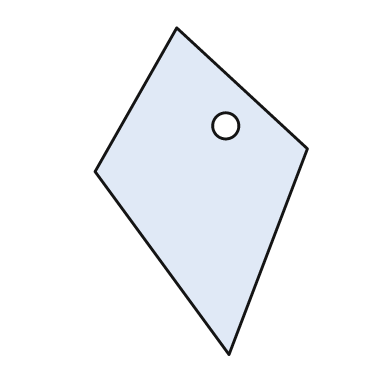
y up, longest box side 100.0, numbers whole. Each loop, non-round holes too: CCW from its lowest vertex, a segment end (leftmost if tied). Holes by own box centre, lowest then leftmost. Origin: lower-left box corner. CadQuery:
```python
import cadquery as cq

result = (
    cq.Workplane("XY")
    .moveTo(41.0, 0.0)
    .lineTo(65.0, 63.0)
    .lineTo(25.0, 100.0)
    .lineTo(0.0, 56.0)
    .close()
    .moveTo(40.0, 70.0)
    .circle(4.0)
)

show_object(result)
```